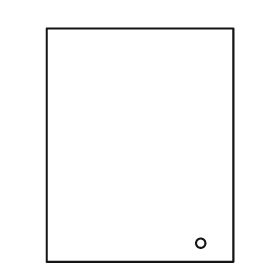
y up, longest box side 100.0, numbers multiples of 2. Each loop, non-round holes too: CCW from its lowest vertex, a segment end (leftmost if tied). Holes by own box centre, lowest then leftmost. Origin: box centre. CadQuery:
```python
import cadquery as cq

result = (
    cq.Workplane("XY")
    .moveTo(-40.0, -50.0)
    .lineTo(40.0, -50.0)
    .lineTo(40.0, 50.0)
    .lineTo(-40.0, 50.0)
    .close()
    .moveTo(26.0, -42.0)
    .circle(2.0)
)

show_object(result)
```